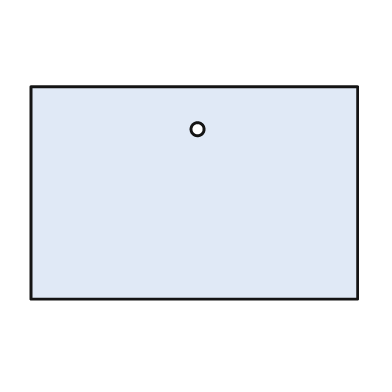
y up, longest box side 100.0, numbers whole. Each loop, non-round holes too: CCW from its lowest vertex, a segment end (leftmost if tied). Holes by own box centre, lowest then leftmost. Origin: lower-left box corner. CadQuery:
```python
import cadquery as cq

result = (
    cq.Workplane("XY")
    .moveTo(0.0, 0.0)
    .lineTo(100.0, 0.0)
    .lineTo(100.0, 65.0)
    .lineTo(0.0, 65.0)
    .close()
    .moveTo(51.0, 52.0)
    .circle(2.0)
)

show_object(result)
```